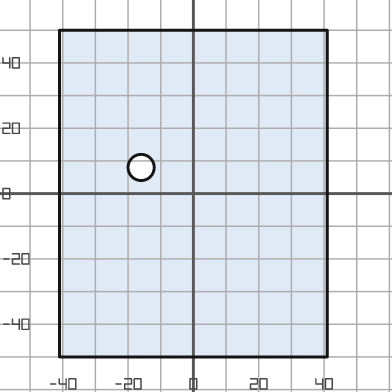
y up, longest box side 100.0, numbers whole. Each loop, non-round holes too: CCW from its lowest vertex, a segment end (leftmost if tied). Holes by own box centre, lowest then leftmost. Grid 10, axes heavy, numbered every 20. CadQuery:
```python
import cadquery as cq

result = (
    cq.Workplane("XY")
    .moveTo(-41.0, -50.0)
    .lineTo(41.0, -50.0)
    .lineTo(41.0, 50.0)
    .lineTo(-41.0, 50.0)
    .close()
    .moveTo(-16.0, 8.0)
    .circle(4.0)
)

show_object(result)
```